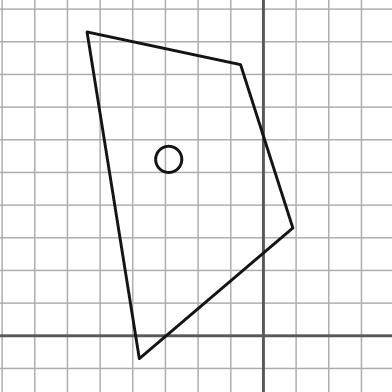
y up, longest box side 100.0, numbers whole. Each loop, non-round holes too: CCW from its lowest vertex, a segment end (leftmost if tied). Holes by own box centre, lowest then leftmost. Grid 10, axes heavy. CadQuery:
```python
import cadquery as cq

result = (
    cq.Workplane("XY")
    .moveTo(-38.0, -7.0)
    .lineTo(9.0, 33.0)
    .lineTo(-7.0, 83.0)
    .lineTo(-54.0, 93.0)
    .close()
    .moveTo(-29.0, 54.0)
    .circle(4.0)
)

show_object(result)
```